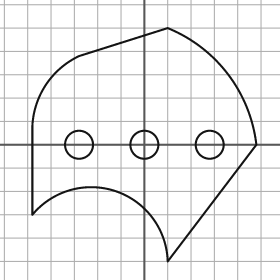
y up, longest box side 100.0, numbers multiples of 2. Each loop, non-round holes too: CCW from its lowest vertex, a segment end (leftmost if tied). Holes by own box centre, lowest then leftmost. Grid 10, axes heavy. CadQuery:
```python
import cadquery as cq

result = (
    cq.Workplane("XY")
    .moveTo(10.0, -50.0)
    .lineTo(48.0, 0.0)
    .threePointArc((36.0, 30.0), (10.0, 50.0))
    .lineTo(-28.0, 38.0)
    .threePointArc((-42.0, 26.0), (-48.0, 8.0))
    .lineTo(-48.0, -30.0)
    .threePointArc((-12.0, -20.0), (10.0, -50.0))
    .close()
    .moveTo(-28.0, 0.0)
    .circle(6.0)
    .moveTo(0.0, 0.0)
    .circle(6.0)
    .moveTo(28.0, 0.0)
    .circle(6.0)
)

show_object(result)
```